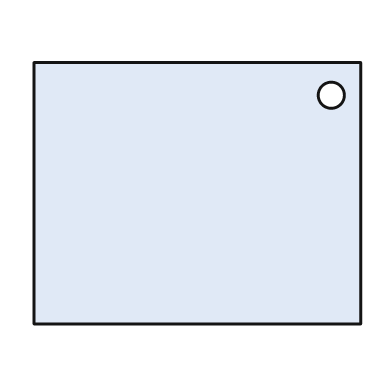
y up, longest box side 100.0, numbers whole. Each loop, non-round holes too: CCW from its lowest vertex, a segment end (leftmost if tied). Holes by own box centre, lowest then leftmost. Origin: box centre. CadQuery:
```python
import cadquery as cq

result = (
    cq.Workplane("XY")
    .moveTo(-50.0, -40.0)
    .lineTo(50.0, -40.0)
    .lineTo(50.0, 40.0)
    .lineTo(-50.0, 40.0)
    .close()
    .moveTo(41.0, 30.0)
    .circle(4.0)
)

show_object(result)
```